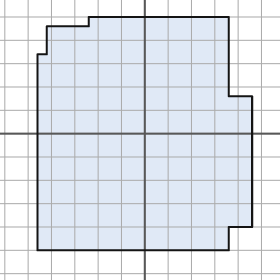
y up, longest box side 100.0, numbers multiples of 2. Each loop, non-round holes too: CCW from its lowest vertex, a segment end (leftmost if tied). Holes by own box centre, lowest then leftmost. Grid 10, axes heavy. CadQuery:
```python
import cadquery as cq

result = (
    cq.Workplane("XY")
    .moveTo(-46.0, -50.0)
    .lineTo(36.0, -50.0)
    .lineTo(36.0, -40.0)
    .lineTo(46.0, -40.0)
    .lineTo(46.0, 16.0)
    .lineTo(36.0, 16.0)
    .lineTo(36.0, 50.0)
    .lineTo(-24.0, 50.0)
    .lineTo(-24.0, 46.0)
    .lineTo(-42.0, 46.0)
    .lineTo(-42.0, 34.0)
    .lineTo(-46.0, 34.0)
    .close()
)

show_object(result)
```